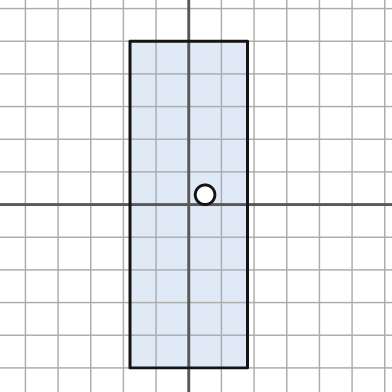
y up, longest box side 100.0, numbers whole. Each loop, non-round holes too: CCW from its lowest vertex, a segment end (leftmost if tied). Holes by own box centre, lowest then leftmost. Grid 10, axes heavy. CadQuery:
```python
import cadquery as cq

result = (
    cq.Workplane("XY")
    .moveTo(-18.0, -50.0)
    .lineTo(18.0, -50.0)
    .lineTo(18.0, 50.0)
    .lineTo(-18.0, 50.0)
    .close()
    .moveTo(5.0, 3.0)
    .circle(3.0)
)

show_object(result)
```